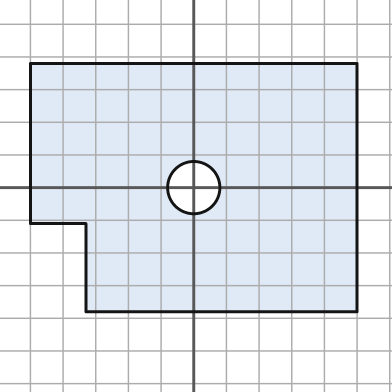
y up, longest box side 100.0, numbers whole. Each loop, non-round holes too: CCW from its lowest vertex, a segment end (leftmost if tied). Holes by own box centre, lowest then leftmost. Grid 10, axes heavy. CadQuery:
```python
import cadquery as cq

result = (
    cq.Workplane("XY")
    .moveTo(-33.0, -38.0)
    .lineTo(50.0, -38.0)
    .lineTo(50.0, 38.0)
    .lineTo(-50.0, 38.0)
    .lineTo(-50.0, -11.0)
    .lineTo(-33.0, -11.0)
    .close()
    .moveTo(0.0, 0.0)
    .circle(8.0)
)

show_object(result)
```